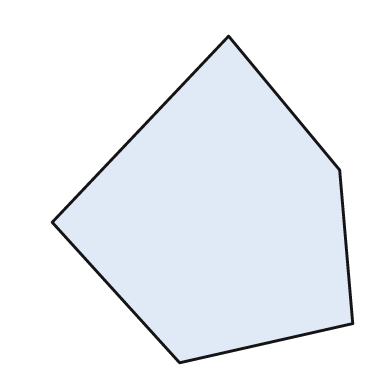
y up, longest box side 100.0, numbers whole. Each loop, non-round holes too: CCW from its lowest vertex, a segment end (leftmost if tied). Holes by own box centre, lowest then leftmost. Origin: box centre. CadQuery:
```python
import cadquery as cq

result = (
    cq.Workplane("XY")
    .moveTo(-7.0, -50.0)
    .lineTo(46.0, -38.0)
    .lineTo(42.0, 9.0)
    .lineTo(8.0, 50.0)
    .lineTo(-46.0, -7.0)
    .close()
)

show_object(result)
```